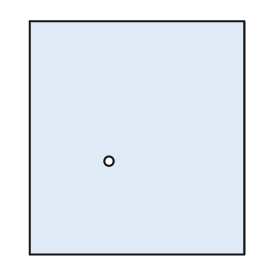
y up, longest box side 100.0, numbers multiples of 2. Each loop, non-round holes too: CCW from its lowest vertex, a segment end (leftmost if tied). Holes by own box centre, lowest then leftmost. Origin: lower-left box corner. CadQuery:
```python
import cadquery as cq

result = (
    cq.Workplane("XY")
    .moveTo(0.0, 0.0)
    .lineTo(92.0, 0.0)
    .lineTo(92.0, 100.0)
    .lineTo(0.0, 100.0)
    .close()
    .moveTo(34.0, 40.0)
    .circle(2.0)
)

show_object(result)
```